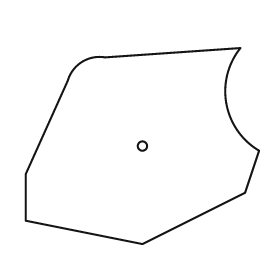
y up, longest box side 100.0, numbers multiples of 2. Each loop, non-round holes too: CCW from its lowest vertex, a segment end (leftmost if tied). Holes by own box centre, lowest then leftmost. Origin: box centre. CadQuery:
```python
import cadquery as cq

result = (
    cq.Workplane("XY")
    .moveTo(0.0, -42.0)
    .lineTo(44.0, -20.0)
    .lineTo(50.0, -2.0)
    .threePointArc((36.0, 18.0), (42.0, 42.0))
    .lineTo(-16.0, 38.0)
    .threePointArc((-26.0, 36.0), (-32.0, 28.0))
    .lineTo(-50.0, -12.0)
    .lineTo(-50.0, -32.0)
    .close()
    .moveTo(0.0, 0.0)
    .circle(2.0)
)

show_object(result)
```